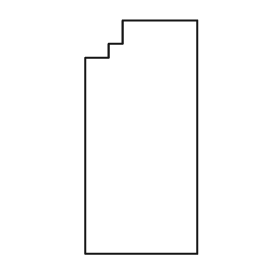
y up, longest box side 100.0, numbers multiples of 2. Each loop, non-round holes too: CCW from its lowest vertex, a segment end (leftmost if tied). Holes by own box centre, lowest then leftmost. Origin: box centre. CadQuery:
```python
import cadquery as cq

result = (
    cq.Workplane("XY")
    .moveTo(-24.0, -50.0)
    .lineTo(24.0, -50.0)
    .lineTo(24.0, 50.0)
    .lineTo(-8.0, 50.0)
    .lineTo(-8.0, 40.0)
    .lineTo(-14.0, 40.0)
    .lineTo(-14.0, 34.0)
    .lineTo(-24.0, 34.0)
    .close()
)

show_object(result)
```